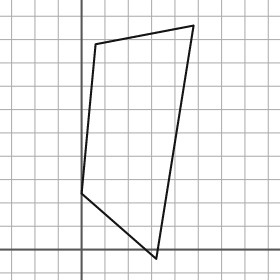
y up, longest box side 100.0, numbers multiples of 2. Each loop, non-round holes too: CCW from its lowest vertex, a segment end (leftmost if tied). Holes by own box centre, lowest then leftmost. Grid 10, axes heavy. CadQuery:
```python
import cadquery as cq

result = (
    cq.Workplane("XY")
    .moveTo(32.0, -4.0)
    .lineTo(48.0, 96.0)
    .lineTo(6.0, 88.0)
    .lineTo(0.0, 24.0)
    .close()
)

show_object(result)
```